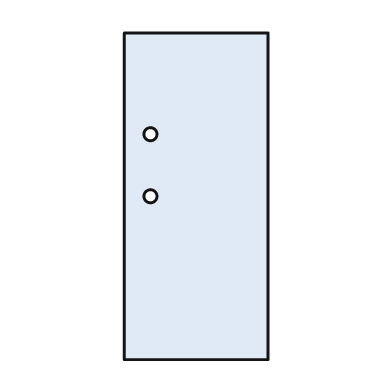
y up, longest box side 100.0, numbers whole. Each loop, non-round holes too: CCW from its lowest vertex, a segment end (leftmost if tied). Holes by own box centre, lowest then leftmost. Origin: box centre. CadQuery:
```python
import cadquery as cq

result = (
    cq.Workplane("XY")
    .moveTo(-22.0, -50.0)
    .lineTo(22.0, -50.0)
    .lineTo(22.0, 50.0)
    .lineTo(-22.0, 50.0)
    .close()
    .moveTo(-14.0, 0.0)
    .circle(2.0)
    .moveTo(-14.0, 19.0)
    .circle(2.0)
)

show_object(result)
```